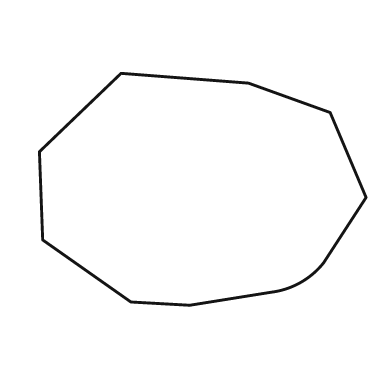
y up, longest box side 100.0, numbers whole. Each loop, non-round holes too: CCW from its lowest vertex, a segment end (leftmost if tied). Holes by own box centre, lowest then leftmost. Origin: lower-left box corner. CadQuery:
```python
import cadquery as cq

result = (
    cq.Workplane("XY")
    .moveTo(46.0, 0.0)
    .lineTo(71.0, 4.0)
    .threePointArc((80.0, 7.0), (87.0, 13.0))
    .lineTo(100.0, 33.0)
    .lineTo(89.0, 59.0)
    .lineTo(64.0, 68.0)
    .lineTo(25.0, 71.0)
    .lineTo(0.0, 47.0)
    .lineTo(1.0, 20.0)
    .lineTo(28.0, 1.0)
    .close()
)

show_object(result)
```